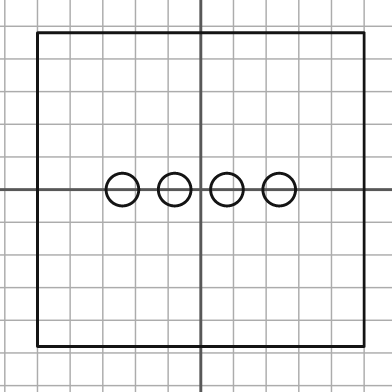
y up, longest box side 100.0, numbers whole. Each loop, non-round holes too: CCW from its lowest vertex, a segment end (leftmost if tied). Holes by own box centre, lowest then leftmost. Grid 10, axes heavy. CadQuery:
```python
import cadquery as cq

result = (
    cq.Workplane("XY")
    .moveTo(-50.0, -48.0)
    .lineTo(50.0, -48.0)
    .lineTo(50.0, 48.0)
    .lineTo(-50.0, 48.0)
    .close()
    .moveTo(-24.0, 0.0)
    .circle(5.0)
    .moveTo(-8.0, 0.0)
    .circle(5.0)
    .moveTo(8.0, 0.0)
    .circle(5.0)
    .moveTo(24.0, 0.0)
    .circle(5.0)
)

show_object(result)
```